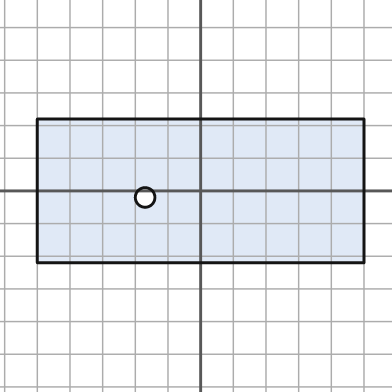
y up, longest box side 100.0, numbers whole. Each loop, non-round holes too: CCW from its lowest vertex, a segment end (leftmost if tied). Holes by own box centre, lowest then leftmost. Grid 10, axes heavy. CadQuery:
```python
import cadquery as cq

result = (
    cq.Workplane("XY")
    .moveTo(-50.0, -22.0)
    .lineTo(50.0, -22.0)
    .lineTo(50.0, 22.0)
    .lineTo(-50.0, 22.0)
    .close()
    .moveTo(-17.0, -2.0)
    .circle(3.0)
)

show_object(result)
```